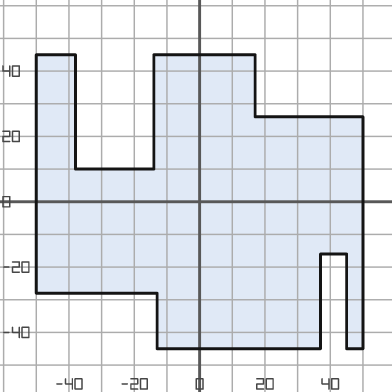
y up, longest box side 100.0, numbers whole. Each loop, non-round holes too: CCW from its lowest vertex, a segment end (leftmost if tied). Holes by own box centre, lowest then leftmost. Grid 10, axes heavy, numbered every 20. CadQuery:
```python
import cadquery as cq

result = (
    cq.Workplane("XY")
    .moveTo(-13.0, -45.0)
    .lineTo(37.0, -45.0)
    .lineTo(37.0, -16.0)
    .lineTo(45.0, -16.0)
    .lineTo(45.0, -45.0)
    .lineTo(50.0, -45.0)
    .lineTo(50.0, 26.0)
    .lineTo(17.0, 26.0)
    .lineTo(17.0, 45.0)
    .lineTo(-14.0, 45.0)
    .lineTo(-14.0, 10.0)
    .lineTo(-38.0, 10.0)
    .lineTo(-38.0, 45.0)
    .lineTo(-50.0, 45.0)
    .lineTo(-50.0, -28.0)
    .lineTo(-13.0, -28.0)
    .close()
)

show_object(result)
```